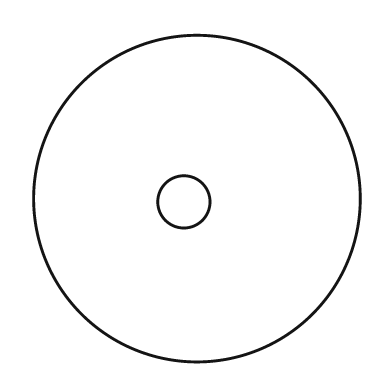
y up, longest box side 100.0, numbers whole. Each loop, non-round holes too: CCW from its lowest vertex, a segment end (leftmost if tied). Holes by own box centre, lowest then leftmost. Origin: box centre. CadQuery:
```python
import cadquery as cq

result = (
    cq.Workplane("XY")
    .moveTo(0.0, 0.0)
    .circle(50.0)
    .moveTo(-4.0, -1.0)
    .circle(8.0)
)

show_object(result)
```